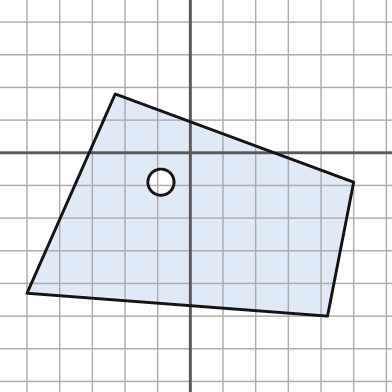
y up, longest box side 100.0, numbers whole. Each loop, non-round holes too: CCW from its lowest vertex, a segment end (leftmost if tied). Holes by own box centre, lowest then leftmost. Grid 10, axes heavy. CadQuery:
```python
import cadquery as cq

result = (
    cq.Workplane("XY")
    .moveTo(42.0, -50.0)
    .lineTo(50.0, -9.0)
    .lineTo(-23.0, 18.0)
    .lineTo(-50.0, -43.0)
    .close()
    .moveTo(-9.0, -9.0)
    .circle(4.0)
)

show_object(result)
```